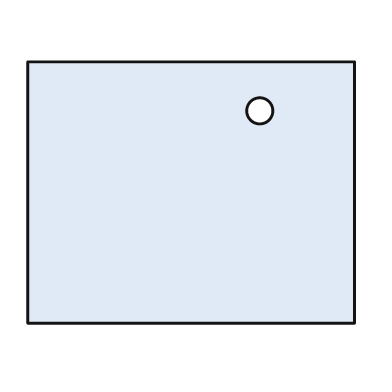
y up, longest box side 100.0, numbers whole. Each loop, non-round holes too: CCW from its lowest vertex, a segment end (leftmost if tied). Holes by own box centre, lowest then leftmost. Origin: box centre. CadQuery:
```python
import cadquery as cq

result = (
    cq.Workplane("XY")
    .moveTo(-50.0, -40.0)
    .lineTo(50.0, -40.0)
    .lineTo(50.0, 40.0)
    .lineTo(-50.0, 40.0)
    .close()
    .moveTo(21.0, 25.0)
    .circle(4.0)
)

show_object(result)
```